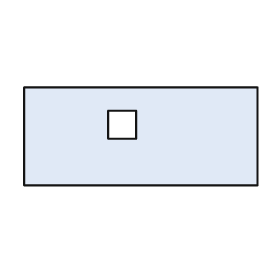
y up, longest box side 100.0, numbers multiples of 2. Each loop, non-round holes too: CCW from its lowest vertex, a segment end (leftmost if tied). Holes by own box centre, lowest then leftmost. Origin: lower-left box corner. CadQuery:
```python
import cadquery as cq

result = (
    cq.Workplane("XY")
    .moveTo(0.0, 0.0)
    .lineTo(100.0, 0.0)
    .lineTo(100.0, 42.0)
    .lineTo(0.0, 42.0)
    .close()
    .moveTo(36.0, 20.0)
    .lineTo(48.0, 20.0)
    .lineTo(48.0, 32.0)
    .lineTo(36.0, 32.0)
    .close()
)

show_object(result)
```